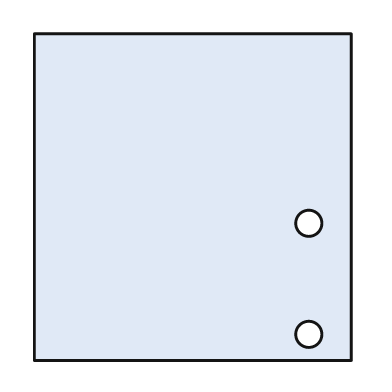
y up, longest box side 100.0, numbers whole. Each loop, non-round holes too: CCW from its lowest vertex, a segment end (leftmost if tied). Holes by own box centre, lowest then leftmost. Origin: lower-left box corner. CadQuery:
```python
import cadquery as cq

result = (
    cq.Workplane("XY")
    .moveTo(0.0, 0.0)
    .lineTo(97.0, 0.0)
    .lineTo(97.0, 100.0)
    .lineTo(0.0, 100.0)
    .close()
    .moveTo(84.0, 8.0)
    .circle(4.0)
    .moveTo(84.0, 42.0)
    .circle(4.0)
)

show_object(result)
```